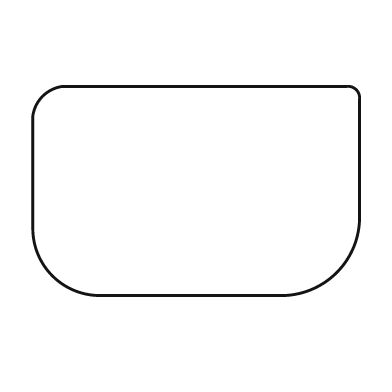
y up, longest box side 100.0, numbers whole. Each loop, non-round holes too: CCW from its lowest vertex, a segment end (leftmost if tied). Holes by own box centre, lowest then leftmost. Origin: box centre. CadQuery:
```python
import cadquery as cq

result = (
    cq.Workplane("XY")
    .moveTo(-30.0, -32.0)
    .lineTo(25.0, -32.0)
    .threePointArc((43.0, -25.0), (50.0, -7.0))
    .lineTo(50.0, 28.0)
    .threePointArc((49.0, 31.0), (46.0, 32.0))
    .lineTo(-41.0, 32.0)
    .threePointArc((-47.0, 29.0), (-50.0, 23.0))
    .lineTo(-50.0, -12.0)
    .threePointArc((-44.0, -26.0), (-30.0, -32.0))
    .close()
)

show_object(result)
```